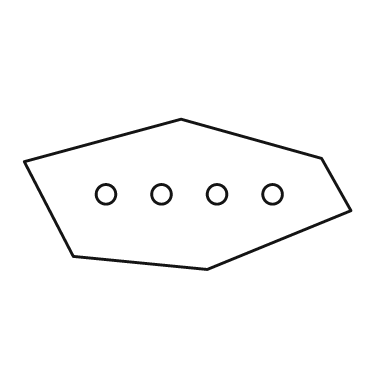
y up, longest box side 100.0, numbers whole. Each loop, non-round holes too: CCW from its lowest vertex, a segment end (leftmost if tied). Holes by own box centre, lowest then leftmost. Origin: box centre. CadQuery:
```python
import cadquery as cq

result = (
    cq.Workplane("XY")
    .moveTo(6.0, -23.0)
    .lineTo(50.0, -5.0)
    .lineTo(41.0, 11.0)
    .lineTo(-2.0, 23.0)
    .lineTo(-50.0, 10.0)
    .lineTo(-35.0, -19.0)
    .close()
    .moveTo(-25.0, 0.0)
    .circle(3.0)
    .moveTo(-8.0, 0.0)
    .circle(3.0)
    .moveTo(9.0, 0.0)
    .circle(3.0)
    .moveTo(26.0, 0.0)
    .circle(3.0)
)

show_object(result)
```